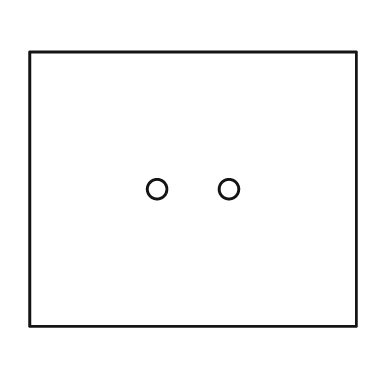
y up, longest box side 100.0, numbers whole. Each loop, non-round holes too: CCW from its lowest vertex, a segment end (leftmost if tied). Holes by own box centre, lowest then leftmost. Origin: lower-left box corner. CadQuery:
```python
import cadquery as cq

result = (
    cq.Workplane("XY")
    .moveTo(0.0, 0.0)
    .lineTo(100.0, 0.0)
    .lineTo(100.0, 84.0)
    .lineTo(0.0, 84.0)
    .close()
    .moveTo(39.0, 42.0)
    .circle(3.0)
    .moveTo(61.0, 42.0)
    .circle(3.0)
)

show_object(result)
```